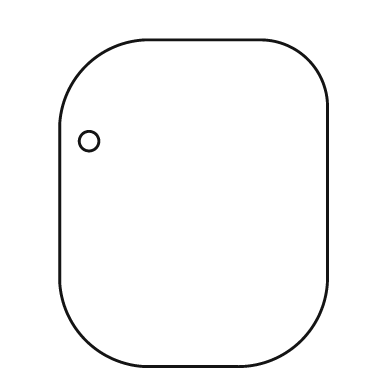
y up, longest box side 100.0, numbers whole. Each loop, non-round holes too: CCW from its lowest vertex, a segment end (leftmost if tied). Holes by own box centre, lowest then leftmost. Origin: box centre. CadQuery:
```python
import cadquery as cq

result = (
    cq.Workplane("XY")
    .moveTo(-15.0, -50.0)
    .lineTo(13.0, -50.0)
    .threePointArc((33.0, -42.0), (41.0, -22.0))
    .lineTo(41.0, 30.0)
    .threePointArc((35.0, 44.0), (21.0, 50.0))
    .lineTo(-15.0, 50.0)
    .threePointArc((-33.0, 42.0), (-41.0, 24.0))
    .lineTo(-41.0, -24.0)
    .threePointArc((-33.0, -42.0), (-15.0, -50.0))
    .close()
    .moveTo(-32.0, 19.0)
    .circle(3.0)
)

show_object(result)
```